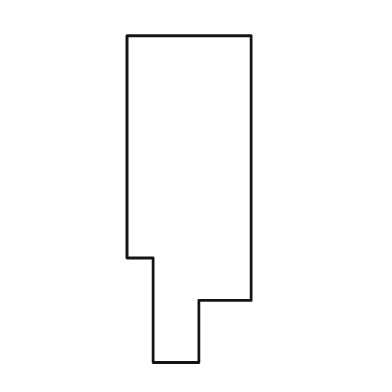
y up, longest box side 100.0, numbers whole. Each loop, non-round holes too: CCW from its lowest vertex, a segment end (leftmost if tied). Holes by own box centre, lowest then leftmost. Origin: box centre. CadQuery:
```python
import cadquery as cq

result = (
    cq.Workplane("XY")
    .moveTo(-11.0, -50.0)
    .lineTo(3.0, -50.0)
    .lineTo(3.0, -31.0)
    .lineTo(19.0, -31.0)
    .lineTo(19.0, 50.0)
    .lineTo(-19.0, 50.0)
    .lineTo(-19.0, -18.0)
    .lineTo(-11.0, -18.0)
    .close()
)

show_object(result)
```